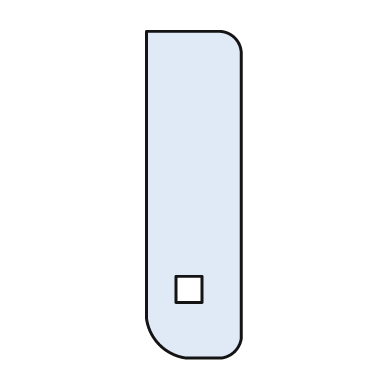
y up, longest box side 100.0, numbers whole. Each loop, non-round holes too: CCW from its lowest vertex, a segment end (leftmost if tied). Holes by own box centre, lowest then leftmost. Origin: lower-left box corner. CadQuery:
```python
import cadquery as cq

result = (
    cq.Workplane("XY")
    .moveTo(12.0, 0.0)
    .lineTo(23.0, 0.0)
    .threePointArc((27.0, 2.0), (29.0, 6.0))
    .lineTo(29.0, 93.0)
    .threePointArc((27.0, 98.0), (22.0, 100.0))
    .lineTo(0.0, 100.0)
    .lineTo(0.0, 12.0)
    .threePointArc((4.0, 4.0), (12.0, 0.0))
    .close()
    .moveTo(9.0, 17.0)
    .lineTo(17.0, 17.0)
    .lineTo(17.0, 25.0)
    .lineTo(9.0, 25.0)
    .close()
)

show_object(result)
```